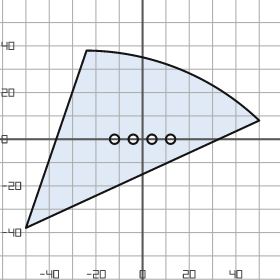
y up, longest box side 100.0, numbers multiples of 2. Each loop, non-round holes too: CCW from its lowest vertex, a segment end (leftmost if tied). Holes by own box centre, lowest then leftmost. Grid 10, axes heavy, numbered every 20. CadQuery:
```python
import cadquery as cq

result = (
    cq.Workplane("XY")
    .moveTo(-50.0, -38.0)
    .lineTo(50.0, 8.0)
    .threePointArc((16.0, 30.0), (-24.0, 38.0))
    .close()
    .moveTo(-12.0, 0.0)
    .circle(2.0)
    .moveTo(-4.0, 0.0)
    .circle(2.0)
    .moveTo(4.0, 0.0)
    .circle(2.0)
    .moveTo(12.0, 0.0)
    .circle(2.0)
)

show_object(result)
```